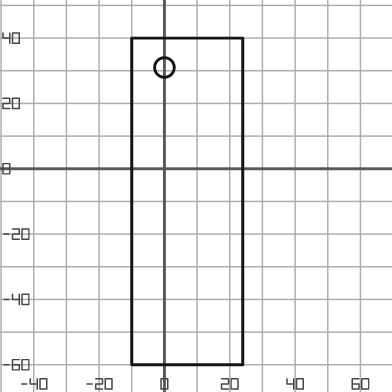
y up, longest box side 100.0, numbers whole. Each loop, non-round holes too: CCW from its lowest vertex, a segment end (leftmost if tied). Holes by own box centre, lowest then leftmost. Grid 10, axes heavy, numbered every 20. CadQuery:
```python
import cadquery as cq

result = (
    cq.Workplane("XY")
    .moveTo(-10.0, -60.0)
    .lineTo(24.0, -60.0)
    .lineTo(24.0, 40.0)
    .lineTo(-10.0, 40.0)
    .close()
    .moveTo(0.0, 31.0)
    .circle(3.0)
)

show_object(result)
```